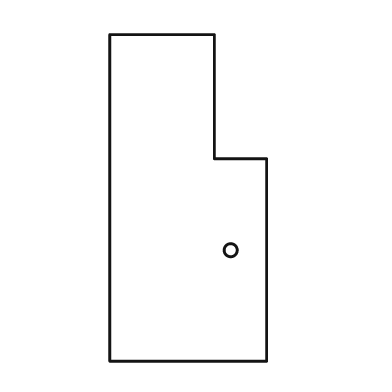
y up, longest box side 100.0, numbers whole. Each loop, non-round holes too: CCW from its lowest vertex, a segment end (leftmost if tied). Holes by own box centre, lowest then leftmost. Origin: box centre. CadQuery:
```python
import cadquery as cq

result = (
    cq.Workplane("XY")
    .moveTo(-24.0, -50.0)
    .lineTo(24.0, -50.0)
    .lineTo(24.0, 12.0)
    .lineTo(8.0, 12.0)
    .lineTo(8.0, 50.0)
    .lineTo(-24.0, 50.0)
    .close()
    .moveTo(13.0, -16.0)
    .circle(2.0)
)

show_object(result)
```